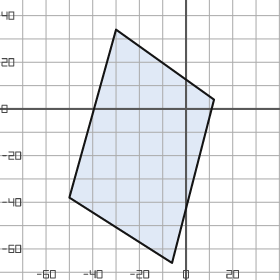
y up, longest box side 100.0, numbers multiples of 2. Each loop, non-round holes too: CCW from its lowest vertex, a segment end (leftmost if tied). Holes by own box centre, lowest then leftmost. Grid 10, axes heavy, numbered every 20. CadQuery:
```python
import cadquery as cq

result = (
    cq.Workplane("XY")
    .moveTo(-6.0, -66.0)
    .lineTo(12.0, 4.0)
    .lineTo(-30.0, 34.0)
    .lineTo(-50.0, -38.0)
    .close()
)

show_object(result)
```